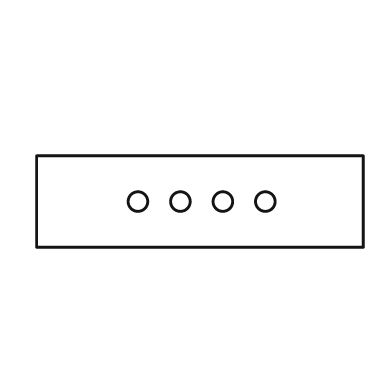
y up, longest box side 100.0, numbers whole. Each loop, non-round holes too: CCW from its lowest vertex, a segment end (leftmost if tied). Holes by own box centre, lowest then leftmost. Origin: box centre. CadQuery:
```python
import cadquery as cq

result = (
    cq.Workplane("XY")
    .moveTo(-50.0, -14.0)
    .lineTo(50.0, -14.0)
    .lineTo(50.0, 14.0)
    .lineTo(-50.0, 14.0)
    .close()
    .moveTo(-19.0, 0.0)
    .circle(3.0)
    .moveTo(-6.0, 0.0)
    .circle(3.0)
    .moveTo(7.0, 0.0)
    .circle(3.0)
    .moveTo(20.0, 0.0)
    .circle(3.0)
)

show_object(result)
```